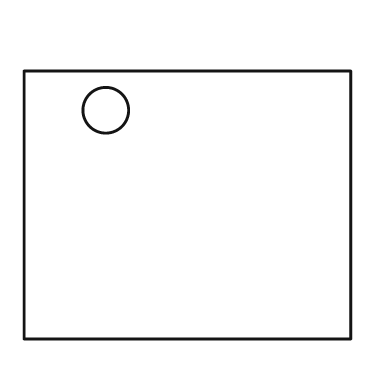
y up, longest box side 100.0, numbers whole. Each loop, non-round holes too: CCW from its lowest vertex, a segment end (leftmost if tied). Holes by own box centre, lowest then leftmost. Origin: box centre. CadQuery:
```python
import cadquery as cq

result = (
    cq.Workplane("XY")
    .moveTo(-50.0, -41.0)
    .lineTo(50.0, -41.0)
    .lineTo(50.0, 41.0)
    .lineTo(-50.0, 41.0)
    .close()
    .moveTo(-25.0, 29.0)
    .circle(7.0)
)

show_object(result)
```